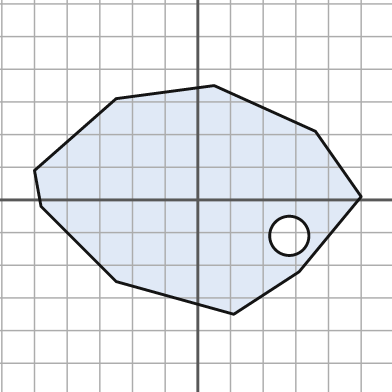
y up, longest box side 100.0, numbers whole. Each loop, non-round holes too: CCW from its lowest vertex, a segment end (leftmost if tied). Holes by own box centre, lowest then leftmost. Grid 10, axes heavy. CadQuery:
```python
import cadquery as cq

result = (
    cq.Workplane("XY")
    .moveTo(11.0, -35.0)
    .lineTo(31.0, -22.0)
    .lineTo(50.0, 1.0)
    .lineTo(36.0, 21.0)
    .lineTo(5.0, 35.0)
    .lineTo(-25.0, 31.0)
    .lineTo(-50.0, 9.0)
    .lineTo(-48.0, -2.0)
    .lineTo(-25.0, -25.0)
    .close()
    .moveTo(28.0, -11.0)
    .circle(6.0)
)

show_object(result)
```